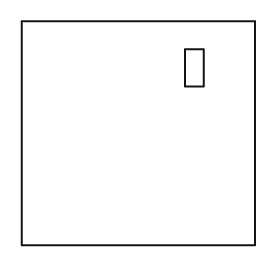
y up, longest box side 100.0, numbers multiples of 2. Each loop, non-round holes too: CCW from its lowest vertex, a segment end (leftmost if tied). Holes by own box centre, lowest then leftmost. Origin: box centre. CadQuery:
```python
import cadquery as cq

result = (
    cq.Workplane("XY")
    .moveTo(-50.0, -48.0)
    .lineTo(50.0, -48.0)
    .lineTo(50.0, 48.0)
    .lineTo(-50.0, 48.0)
    .close()
    .moveTo(20.0, 20.0)
    .lineTo(28.0, 20.0)
    .lineTo(28.0, 36.0)
    .lineTo(20.0, 36.0)
    .close()
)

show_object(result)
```